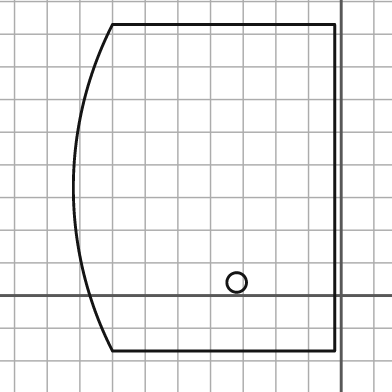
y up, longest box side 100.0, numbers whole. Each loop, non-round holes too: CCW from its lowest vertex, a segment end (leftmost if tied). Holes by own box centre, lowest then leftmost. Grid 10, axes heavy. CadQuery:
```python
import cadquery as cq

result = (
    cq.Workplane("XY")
    .moveTo(-70.0, -17.0)
    .lineTo(-2.0, -17.0)
    .lineTo(-2.0, 83.0)
    .lineTo(-70.0, 83.0)
    .threePointArc((-82.0, 33.0), (-70.0, -17.0))
    .close()
    .moveTo(-32.0, 4.0)
    .circle(3.0)
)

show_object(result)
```